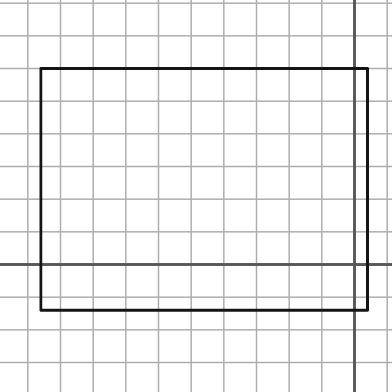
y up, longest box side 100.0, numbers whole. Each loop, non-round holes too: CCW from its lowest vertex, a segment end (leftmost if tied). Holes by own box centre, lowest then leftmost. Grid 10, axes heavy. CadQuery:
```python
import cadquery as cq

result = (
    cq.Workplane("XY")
    .moveTo(-96.0, -14.0)
    .lineTo(4.0, -14.0)
    .lineTo(4.0, 60.0)
    .lineTo(-96.0, 60.0)
    .close()
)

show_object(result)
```